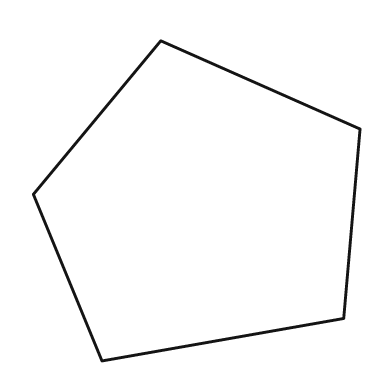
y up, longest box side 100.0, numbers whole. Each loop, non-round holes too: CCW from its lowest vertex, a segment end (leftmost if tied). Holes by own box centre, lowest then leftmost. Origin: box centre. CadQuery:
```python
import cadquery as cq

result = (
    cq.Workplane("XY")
    .moveTo(-29.0, -49.0)
    .lineTo(45.0, -36.0)
    .lineTo(50.0, 22.0)
    .lineTo(-11.0, 49.0)
    .lineTo(-50.0, 2.0)
    .close()
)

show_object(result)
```